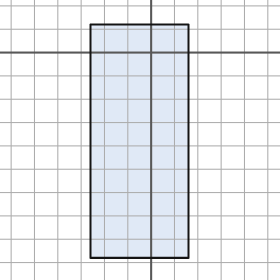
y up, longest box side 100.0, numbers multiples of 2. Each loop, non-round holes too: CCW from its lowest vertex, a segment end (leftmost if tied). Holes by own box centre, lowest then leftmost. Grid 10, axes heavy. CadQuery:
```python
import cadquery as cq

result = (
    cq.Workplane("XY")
    .moveTo(-26.0, -88.0)
    .lineTo(16.0, -88.0)
    .lineTo(16.0, 12.0)
    .lineTo(-26.0, 12.0)
    .close()
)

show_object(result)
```